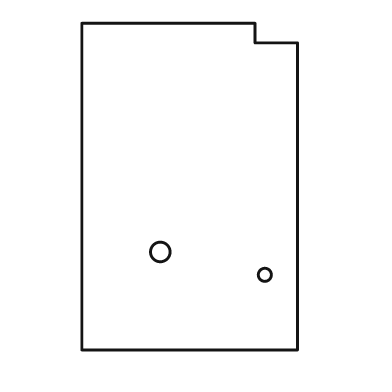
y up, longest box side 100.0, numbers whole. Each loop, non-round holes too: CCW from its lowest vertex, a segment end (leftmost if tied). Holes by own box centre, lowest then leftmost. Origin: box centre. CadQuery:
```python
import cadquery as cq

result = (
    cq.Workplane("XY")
    .moveTo(-33.0, -50.0)
    .lineTo(33.0, -50.0)
    .lineTo(33.0, 44.0)
    .lineTo(20.0, 44.0)
    .lineTo(20.0, 50.0)
    .lineTo(-33.0, 50.0)
    .close()
    .moveTo(23.0, -27.0)
    .circle(2.0)
    .moveTo(-9.0, -20.0)
    .circle(3.0)
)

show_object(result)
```